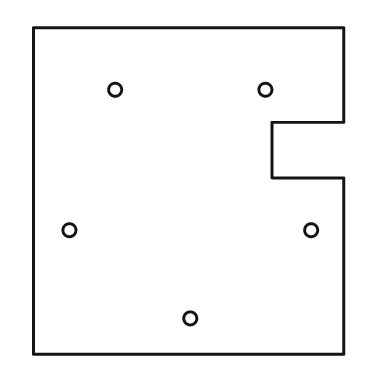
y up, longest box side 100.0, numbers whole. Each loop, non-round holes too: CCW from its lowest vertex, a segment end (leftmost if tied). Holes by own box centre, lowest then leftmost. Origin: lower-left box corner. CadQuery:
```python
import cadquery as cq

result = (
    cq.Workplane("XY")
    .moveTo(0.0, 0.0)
    .lineTo(95.0, 0.0)
    .lineTo(95.0, 54.0)
    .lineTo(73.0, 54.0)
    .lineTo(73.0, 71.0)
    .lineTo(95.0, 71.0)
    .lineTo(95.0, 100.0)
    .lineTo(0.0, 100.0)
    .close()
    .moveTo(48.0, 11.0)
    .circle(2.0)
    .moveTo(11.0, 38.0)
    .circle(2.0)
    .moveTo(85.0, 38.0)
    .circle(2.0)
    .moveTo(25.0, 81.0)
    .circle(2.0)
    .moveTo(71.0, 81.0)
    .circle(2.0)
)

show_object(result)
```